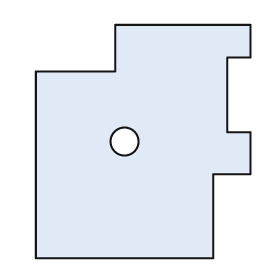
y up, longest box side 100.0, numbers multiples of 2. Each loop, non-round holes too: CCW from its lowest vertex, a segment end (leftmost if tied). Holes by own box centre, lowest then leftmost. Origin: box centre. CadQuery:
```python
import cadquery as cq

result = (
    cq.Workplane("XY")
    .moveTo(-46.0, -50.0)
    .lineTo(30.0, -50.0)
    .lineTo(30.0, -14.0)
    .lineTo(46.0, -14.0)
    .lineTo(46.0, 4.0)
    .lineTo(36.0, 4.0)
    .lineTo(36.0, 36.0)
    .lineTo(46.0, 36.0)
    .lineTo(46.0, 50.0)
    .lineTo(-12.0, 50.0)
    .lineTo(-12.0, 30.0)
    .lineTo(-46.0, 30.0)
    .close()
    .moveTo(-8.0, 0.0)
    .circle(6.0)
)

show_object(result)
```